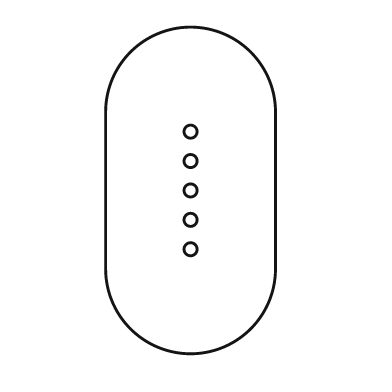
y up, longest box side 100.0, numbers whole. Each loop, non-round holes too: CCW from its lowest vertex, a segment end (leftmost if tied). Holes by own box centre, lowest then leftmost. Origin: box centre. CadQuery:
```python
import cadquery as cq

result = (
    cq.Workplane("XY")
    .moveTo(-26.0, -24.0)
    .threePointArc((0.0, -50.0), (26.0, -24.0))
    .lineTo(26.0, 24.0)
    .threePointArc((0.0, 50.0), (-26.0, 24.0))
    .close()
    .moveTo(0.0, -18.0)
    .circle(2.0)
    .moveTo(0.0, -9.0)
    .circle(2.0)
    .moveTo(0.0, 0.0)
    .circle(2.0)
    .moveTo(0.0, 9.0)
    .circle(2.0)
    .moveTo(0.0, 18.0)
    .circle(2.0)
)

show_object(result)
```